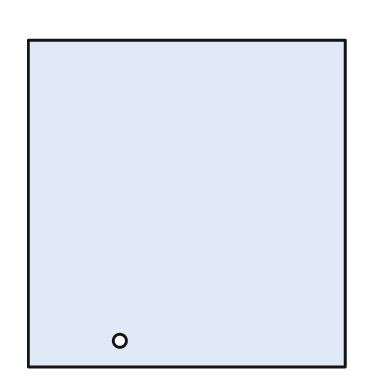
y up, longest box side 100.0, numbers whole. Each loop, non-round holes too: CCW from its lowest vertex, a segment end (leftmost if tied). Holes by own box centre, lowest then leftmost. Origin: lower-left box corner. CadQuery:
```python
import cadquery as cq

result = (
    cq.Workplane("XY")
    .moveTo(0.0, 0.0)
    .lineTo(97.0, 0.0)
    .lineTo(97.0, 100.0)
    .lineTo(0.0, 100.0)
    .close()
    .moveTo(28.0, 8.0)
    .circle(2.0)
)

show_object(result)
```